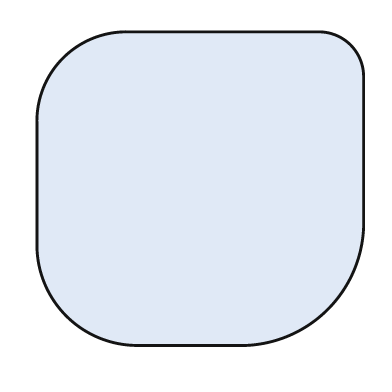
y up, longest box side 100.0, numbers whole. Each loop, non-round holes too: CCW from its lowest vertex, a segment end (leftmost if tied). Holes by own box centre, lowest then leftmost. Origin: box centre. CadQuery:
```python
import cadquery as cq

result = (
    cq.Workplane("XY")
    .moveTo(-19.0, -48.0)
    .lineTo(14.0, -48.0)
    .threePointArc((39.0, -37.0), (50.0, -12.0))
    .lineTo(50.0, 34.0)
    .threePointArc((46.0, 44.0), (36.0, 48.0))
    .lineTo(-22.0, 48.0)
    .threePointArc((-42.0, 40.0), (-50.0, 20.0))
    .lineTo(-50.0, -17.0)
    .threePointArc((-41.0, -39.0), (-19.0, -48.0))
    .close()
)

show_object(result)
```